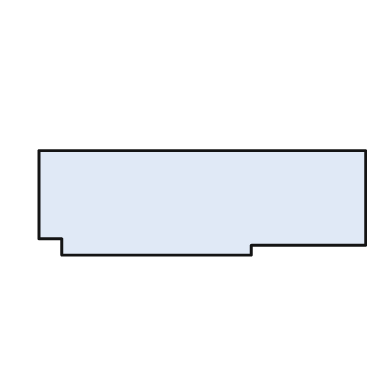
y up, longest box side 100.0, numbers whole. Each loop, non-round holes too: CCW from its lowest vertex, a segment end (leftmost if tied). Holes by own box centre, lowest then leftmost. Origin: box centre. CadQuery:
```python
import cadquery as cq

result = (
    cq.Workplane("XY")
    .moveTo(-43.0, -16.0)
    .lineTo(15.0, -16.0)
    .lineTo(15.0, -13.0)
    .lineTo(50.0, -13.0)
    .lineTo(50.0, 16.0)
    .lineTo(-50.0, 16.0)
    .lineTo(-50.0, -11.0)
    .lineTo(-43.0, -11.0)
    .close()
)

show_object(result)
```